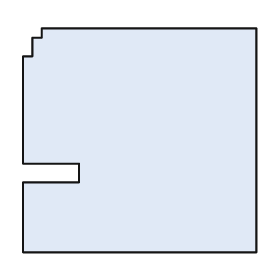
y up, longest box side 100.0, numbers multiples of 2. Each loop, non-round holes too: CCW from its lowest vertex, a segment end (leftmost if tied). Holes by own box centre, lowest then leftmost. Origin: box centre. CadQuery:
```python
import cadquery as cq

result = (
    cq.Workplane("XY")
    .moveTo(-50.0, -48.0)
    .lineTo(50.0, -48.0)
    .lineTo(50.0, 48.0)
    .lineTo(-42.0, 48.0)
    .lineTo(-42.0, 44.0)
    .lineTo(-46.0, 44.0)
    .lineTo(-46.0, 36.0)
    .lineTo(-50.0, 36.0)
    .lineTo(-50.0, -10.0)
    .lineTo(-26.0, -10.0)
    .lineTo(-26.0, -18.0)
    .lineTo(-50.0, -18.0)
    .close()
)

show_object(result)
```